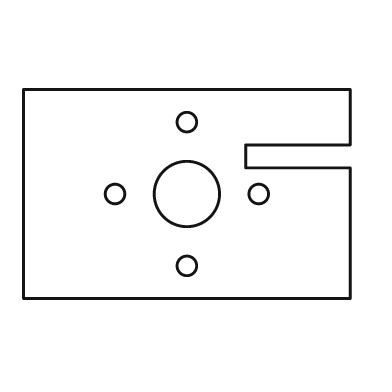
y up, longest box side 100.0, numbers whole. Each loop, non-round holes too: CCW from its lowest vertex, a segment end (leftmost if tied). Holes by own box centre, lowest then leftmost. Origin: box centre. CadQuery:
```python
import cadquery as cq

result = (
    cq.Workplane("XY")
    .moveTo(-50.0, -32.0)
    .lineTo(50.0, -32.0)
    .lineTo(50.0, 8.0)
    .lineTo(18.0, 8.0)
    .lineTo(18.0, 15.0)
    .lineTo(50.0, 15.0)
    .lineTo(50.0, 32.0)
    .lineTo(-50.0, 32.0)
    .close()
    .moveTo(0.0, -22.0)
    .circle(3.0)
    .moveTo(-22.0, 0.0)
    .circle(3.0)
    .moveTo(0.0, 0.0)
    .circle(10.0)
    .moveTo(22.0, 0.0)
    .circle(3.0)
    .moveTo(0.0, 22.0)
    .circle(3.0)
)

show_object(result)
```